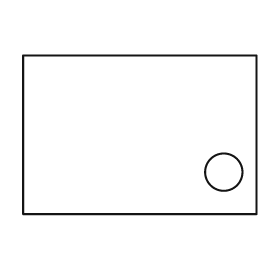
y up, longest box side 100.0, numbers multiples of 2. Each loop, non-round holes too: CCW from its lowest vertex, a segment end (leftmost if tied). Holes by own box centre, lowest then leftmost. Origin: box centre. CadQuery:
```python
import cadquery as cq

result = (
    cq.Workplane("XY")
    .moveTo(-50.0, -34.0)
    .lineTo(50.0, -34.0)
    .lineTo(50.0, 34.0)
    .lineTo(-50.0, 34.0)
    .close()
    .moveTo(36.0, -16.0)
    .circle(8.0)
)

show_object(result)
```